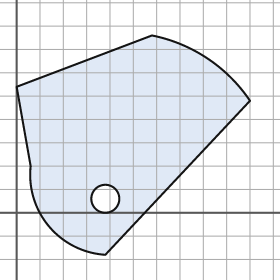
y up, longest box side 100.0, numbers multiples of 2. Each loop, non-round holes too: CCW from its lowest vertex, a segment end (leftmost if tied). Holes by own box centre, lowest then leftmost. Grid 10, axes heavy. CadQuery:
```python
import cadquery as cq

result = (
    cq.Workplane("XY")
    .moveTo(38.0, -18.0)
    .lineTo(100.0, 48.0)
    .threePointArc((82.0, 66.0), (58.0, 76.0))
    .lineTo(0.0, 54.0)
    .lineTo(6.0, 20.0)
    .threePointArc((14.0, -6.0), (38.0, -18.0))
    .close()
    .moveTo(38.0, 6.0)
    .circle(6.0)
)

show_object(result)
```